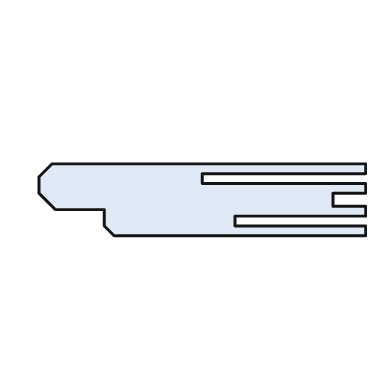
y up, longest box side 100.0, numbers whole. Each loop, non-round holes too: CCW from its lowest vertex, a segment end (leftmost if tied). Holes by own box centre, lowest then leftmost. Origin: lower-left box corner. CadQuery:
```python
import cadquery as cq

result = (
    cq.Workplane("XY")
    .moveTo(23.0, 0.0)
    .lineTo(100.0, 0.0)
    .lineTo(100.0, 3.0)
    .lineTo(60.0, 3.0)
    .lineTo(60.0, 6.0)
    .lineTo(100.0, 6.0)
    .lineTo(100.0, 9.0)
    .lineTo(90.0, 9.0)
    .lineTo(90.0, 13.0)
    .lineTo(100.0, 13.0)
    .lineTo(100.0, 16.0)
    .lineTo(50.0, 16.0)
    .lineTo(50.0, 19.0)
    .lineTo(100.0, 19.0)
    .lineTo(100.0, 22.0)
    .lineTo(4.0, 22.0)
    .lineTo(0.0, 18.0)
    .lineTo(0.0, 13.0)
    .lineTo(5.0, 8.0)
    .lineTo(20.0, 8.0)
    .lineTo(20.0, 3.0)
    .close()
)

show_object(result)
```